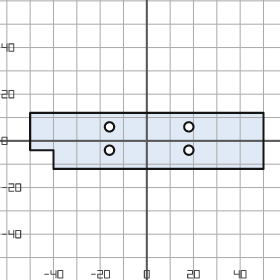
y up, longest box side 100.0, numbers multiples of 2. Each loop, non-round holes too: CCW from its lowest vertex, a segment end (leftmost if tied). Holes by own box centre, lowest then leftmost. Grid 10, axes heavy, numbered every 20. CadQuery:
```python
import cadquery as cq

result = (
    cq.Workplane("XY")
    .moveTo(-40.0, -12.0)
    .lineTo(50.0, -12.0)
    .lineTo(50.0, 12.0)
    .lineTo(-50.0, 12.0)
    .lineTo(-50.0, -4.0)
    .lineTo(-40.0, -4.0)
    .close()
    .moveTo(-16.0, -4.0)
    .circle(2.0)
    .moveTo(18.0, -4.0)
    .circle(2.0)
    .moveTo(-16.0, 6.0)
    .circle(2.0)
    .moveTo(18.0, 6.0)
    .circle(2.0)
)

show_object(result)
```